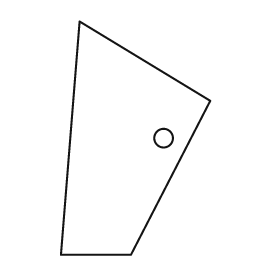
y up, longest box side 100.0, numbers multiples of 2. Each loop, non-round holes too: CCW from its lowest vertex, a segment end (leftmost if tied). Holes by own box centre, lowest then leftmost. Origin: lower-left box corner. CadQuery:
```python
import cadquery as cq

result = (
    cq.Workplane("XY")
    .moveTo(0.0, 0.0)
    .lineTo(30.0, 0.0)
    .lineTo(64.0, 66.0)
    .lineTo(8.0, 100.0)
    .close()
    .moveTo(44.0, 50.0)
    .circle(4.0)
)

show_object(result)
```